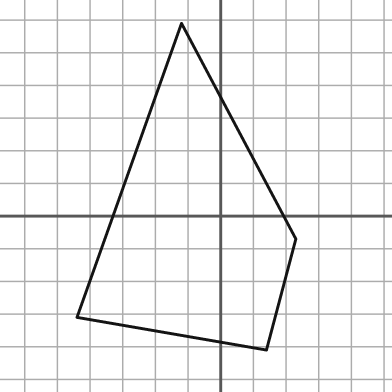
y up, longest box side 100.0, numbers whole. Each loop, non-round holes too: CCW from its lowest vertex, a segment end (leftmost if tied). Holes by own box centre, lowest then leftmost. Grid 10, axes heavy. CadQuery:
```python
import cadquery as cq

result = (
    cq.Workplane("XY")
    .moveTo(14.0, -41.0)
    .lineTo(23.0, -7.0)
    .lineTo(-12.0, 59.0)
    .lineTo(-44.0, -31.0)
    .close()
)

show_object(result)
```